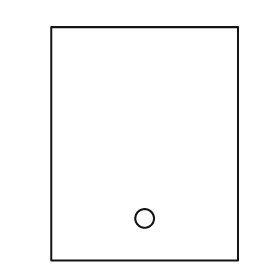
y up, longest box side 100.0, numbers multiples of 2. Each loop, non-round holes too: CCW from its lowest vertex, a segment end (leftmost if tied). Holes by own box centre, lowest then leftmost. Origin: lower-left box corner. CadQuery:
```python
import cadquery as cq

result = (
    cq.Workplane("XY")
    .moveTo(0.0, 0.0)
    .lineTo(80.0, 0.0)
    .lineTo(80.0, 100.0)
    .lineTo(0.0, 100.0)
    .close()
    .moveTo(40.0, 18.0)
    .circle(4.0)
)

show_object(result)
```